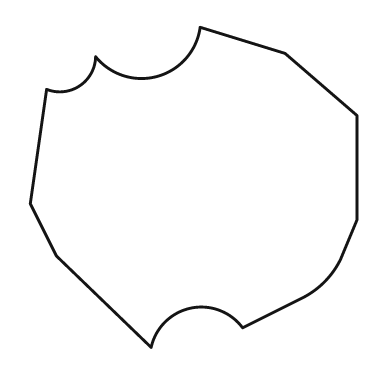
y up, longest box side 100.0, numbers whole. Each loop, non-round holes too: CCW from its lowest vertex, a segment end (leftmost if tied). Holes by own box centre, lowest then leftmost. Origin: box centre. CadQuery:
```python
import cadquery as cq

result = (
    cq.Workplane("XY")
    .moveTo(-13.0, -49.0)
    .threePointArc((-1.0, -37.0), (15.0, -43.0))
    .lineTo(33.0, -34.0)
    .threePointArc((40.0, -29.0), (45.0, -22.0))
    .lineTo(50.0, -10.0)
    .lineTo(50.0, 22.0)
    .lineTo(28.0, 41.0)
    .lineTo(2.0, 49.0)
    .threePointArc((-11.0, 34.0), (-30.0, 40.0))
    .threePointArc((-35.0, 31.0), (-45.0, 30.0))
    .lineTo(-50.0, -5.0)
    .lineTo(-42.0, -21.0)
    .close()
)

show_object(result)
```